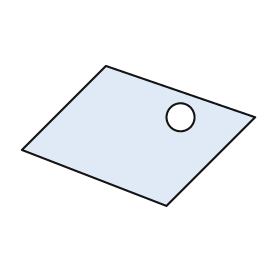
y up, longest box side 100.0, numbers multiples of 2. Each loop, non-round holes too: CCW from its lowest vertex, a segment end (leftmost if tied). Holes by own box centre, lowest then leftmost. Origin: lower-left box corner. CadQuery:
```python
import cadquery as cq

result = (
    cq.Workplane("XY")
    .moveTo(62.0, 0.0)
    .lineTo(100.0, 38.0)
    .lineTo(36.0, 60.0)
    .lineTo(0.0, 24.0)
    .close()
    .moveTo(68.0, 38.0)
    .circle(6.0)
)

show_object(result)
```